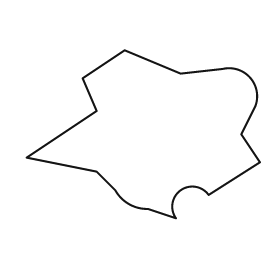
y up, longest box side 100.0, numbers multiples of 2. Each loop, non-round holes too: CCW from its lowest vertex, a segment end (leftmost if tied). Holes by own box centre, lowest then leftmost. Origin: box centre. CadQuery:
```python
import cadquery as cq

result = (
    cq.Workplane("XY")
    .moveTo(14.0, -36.0)
    .threePointArc((16.0, -24.0), (28.0, -26.0))
    .lineTo(50.0, -12.0)
    .lineTo(42.0, 0.0)
    .lineTo(48.0, 12.0)
    .threePointArc((46.0, 24.0), (34.0, 28.0))
    .lineTo(16.0, 26.0)
    .lineTo(-8.0, 36.0)
    .lineTo(-26.0, 24.0)
    .lineTo(-20.0, 10.0)
    .lineTo(-50.0, -10.0)
    .lineTo(-20.0, -16.0)
    .lineTo(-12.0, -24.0)
    .threePointArc((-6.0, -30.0), (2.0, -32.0))
    .close()
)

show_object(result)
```